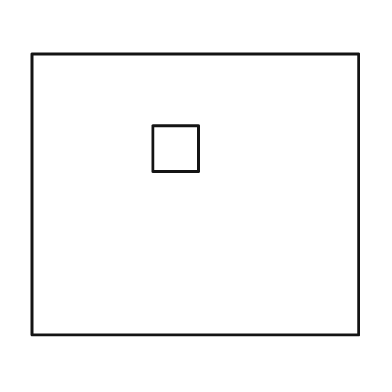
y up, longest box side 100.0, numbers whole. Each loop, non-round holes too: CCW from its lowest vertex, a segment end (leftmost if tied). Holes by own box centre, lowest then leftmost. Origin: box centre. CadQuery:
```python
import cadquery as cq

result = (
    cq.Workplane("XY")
    .moveTo(-50.0, -43.0)
    .lineTo(50.0, -43.0)
    .lineTo(50.0, 43.0)
    .lineTo(-50.0, 43.0)
    .close()
    .moveTo(-13.0, 7.0)
    .lineTo(1.0, 7.0)
    .lineTo(1.0, 21.0)
    .lineTo(-13.0, 21.0)
    .close()
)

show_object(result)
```